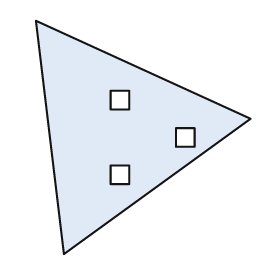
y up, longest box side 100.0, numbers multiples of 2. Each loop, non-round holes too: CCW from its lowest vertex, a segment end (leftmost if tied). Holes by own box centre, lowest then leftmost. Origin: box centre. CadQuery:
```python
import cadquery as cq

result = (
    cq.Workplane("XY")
    .moveTo(-34.0, -50.0)
    .lineTo(46.0, 8.0)
    .lineTo(-46.0, 50.0)
    .close()
    .moveTo(-14.0, -20.0)
    .lineTo(-6.0, -20.0)
    .lineTo(-6.0, -12.0)
    .lineTo(-14.0, -12.0)
    .close()
    .moveTo(14.0, -4.0)
    .lineTo(22.0, -4.0)
    .lineTo(22.0, 4.0)
    .lineTo(14.0, 4.0)
    .close()
    .moveTo(-14.0, 12.0)
    .lineTo(-6.0, 12.0)
    .lineTo(-6.0, 20.0)
    .lineTo(-14.0, 20.0)
    .close()
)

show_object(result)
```